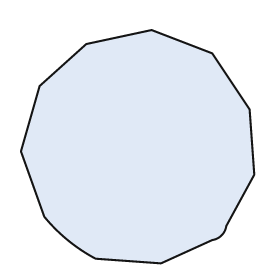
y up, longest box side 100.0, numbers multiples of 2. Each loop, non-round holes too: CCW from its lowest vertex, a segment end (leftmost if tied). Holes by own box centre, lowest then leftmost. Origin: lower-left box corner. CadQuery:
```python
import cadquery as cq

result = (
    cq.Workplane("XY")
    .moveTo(60.0, 0.0)
    .lineTo(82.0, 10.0)
    .threePointArc((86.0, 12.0), (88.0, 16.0))
    .lineTo(100.0, 38.0)
    .lineTo(98.0, 66.0)
    .lineTo(82.0, 90.0)
    .lineTo(56.0, 100.0)
    .lineTo(28.0, 94.0)
    .lineTo(8.0, 76.0)
    .lineTo(0.0, 48.0)
    .lineTo(10.0, 20.0)
    .threePointArc((20.0, 10.0), (32.0, 2.0))
    .close()
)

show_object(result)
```